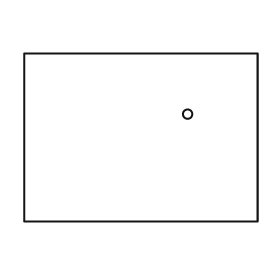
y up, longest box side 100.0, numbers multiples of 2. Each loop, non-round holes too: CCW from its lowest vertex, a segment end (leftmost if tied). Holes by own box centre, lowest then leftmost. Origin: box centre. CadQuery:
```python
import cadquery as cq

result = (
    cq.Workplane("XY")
    .moveTo(-50.0, -36.0)
    .lineTo(50.0, -36.0)
    .lineTo(50.0, 36.0)
    .lineTo(-50.0, 36.0)
    .close()
    .moveTo(20.0, 10.0)
    .circle(2.0)
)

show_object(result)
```